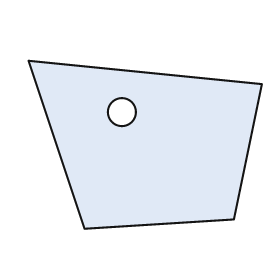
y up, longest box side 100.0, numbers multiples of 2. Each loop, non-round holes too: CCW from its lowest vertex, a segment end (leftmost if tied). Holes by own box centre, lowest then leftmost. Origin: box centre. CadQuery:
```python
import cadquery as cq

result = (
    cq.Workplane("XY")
    .moveTo(-26.0, -36.0)
    .lineTo(38.0, -32.0)
    .lineTo(50.0, 26.0)
    .lineTo(-50.0, 36.0)
    .close()
    .moveTo(-10.0, 14.0)
    .circle(6.0)
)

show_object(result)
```